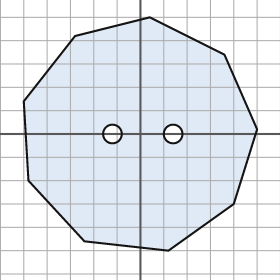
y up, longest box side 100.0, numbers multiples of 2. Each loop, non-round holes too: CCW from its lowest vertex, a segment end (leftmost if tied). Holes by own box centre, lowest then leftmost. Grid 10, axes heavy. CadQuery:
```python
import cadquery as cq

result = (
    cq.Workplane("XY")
    .moveTo(12.0, -50.0)
    .lineTo(40.0, -30.0)
    .lineTo(50.0, 2.0)
    .lineTo(36.0, 34.0)
    .lineTo(4.0, 50.0)
    .lineTo(-28.0, 42.0)
    .lineTo(-50.0, 14.0)
    .lineTo(-48.0, -20.0)
    .lineTo(-24.0, -46.0)
    .close()
    .moveTo(-12.0, 0.0)
    .circle(4.0)
    .moveTo(14.0, 0.0)
    .circle(4.0)
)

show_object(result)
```